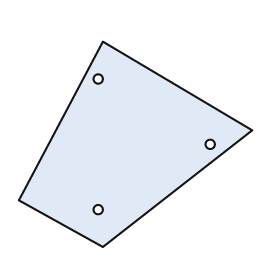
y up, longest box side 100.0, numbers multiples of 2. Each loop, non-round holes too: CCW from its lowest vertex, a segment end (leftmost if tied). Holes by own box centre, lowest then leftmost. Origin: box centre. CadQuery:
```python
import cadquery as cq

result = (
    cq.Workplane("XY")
    .moveTo(-14.0, -44.0)
    .lineTo(50.0, 6.0)
    .lineTo(-14.0, 44.0)
    .lineTo(-50.0, -24.0)
    .close()
    .moveTo(-16.0, -28.0)
    .circle(2.0)
    .moveTo(32.0, 0.0)
    .circle(2.0)
    .moveTo(-16.0, 28.0)
    .circle(2.0)
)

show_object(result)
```